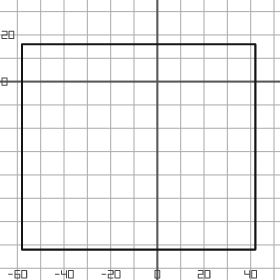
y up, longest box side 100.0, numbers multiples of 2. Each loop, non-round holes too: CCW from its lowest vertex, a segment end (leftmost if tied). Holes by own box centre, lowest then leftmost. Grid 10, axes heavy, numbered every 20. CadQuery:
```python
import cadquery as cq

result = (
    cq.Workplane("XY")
    .moveTo(-58.0, -72.0)
    .lineTo(42.0, -72.0)
    .lineTo(42.0, 16.0)
    .lineTo(-58.0, 16.0)
    .close()
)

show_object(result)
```